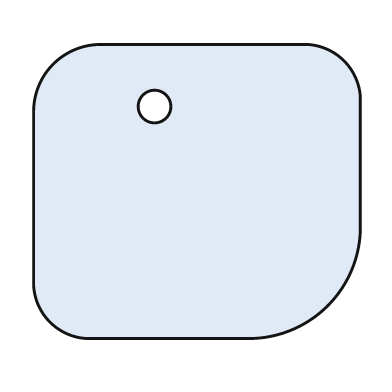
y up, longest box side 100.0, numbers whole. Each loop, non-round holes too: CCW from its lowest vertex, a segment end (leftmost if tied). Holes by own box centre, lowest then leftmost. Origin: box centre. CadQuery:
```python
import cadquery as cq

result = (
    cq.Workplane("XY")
    .moveTo(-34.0, -45.0)
    .lineTo(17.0, -45.0)
    .threePointArc((40.0, -35.0), (50.0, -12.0))
    .lineTo(50.0, 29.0)
    .threePointArc((45.0, 40.0), (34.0, 45.0))
    .lineTo(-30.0, 45.0)
    .threePointArc((-44.0, 39.0), (-50.0, 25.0))
    .lineTo(-50.0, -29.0)
    .threePointArc((-45.0, -40.0), (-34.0, -45.0))
    .close()
    .moveTo(-13.0, 26.0)
    .circle(5.0)
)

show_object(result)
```